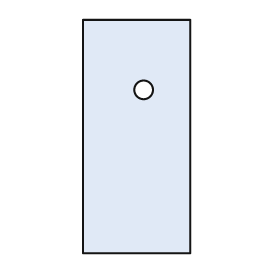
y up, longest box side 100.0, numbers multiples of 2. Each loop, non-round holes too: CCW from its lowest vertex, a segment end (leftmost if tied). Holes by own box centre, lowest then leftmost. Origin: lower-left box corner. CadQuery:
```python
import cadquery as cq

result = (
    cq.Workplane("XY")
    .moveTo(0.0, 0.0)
    .lineTo(46.0, 0.0)
    .lineTo(46.0, 100.0)
    .lineTo(0.0, 100.0)
    .close()
    .moveTo(26.0, 70.0)
    .circle(4.0)
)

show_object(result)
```